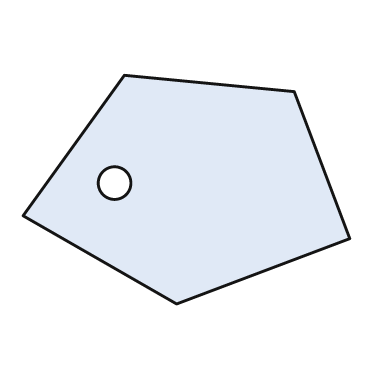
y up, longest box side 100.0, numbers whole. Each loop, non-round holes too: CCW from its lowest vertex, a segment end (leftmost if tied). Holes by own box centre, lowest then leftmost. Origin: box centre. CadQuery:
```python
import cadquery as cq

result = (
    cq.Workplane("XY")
    .moveTo(-3.0, -35.0)
    .lineTo(50.0, -15.0)
    .lineTo(33.0, 30.0)
    .lineTo(-19.0, 35.0)
    .lineTo(-50.0, -8.0)
    .close()
    .moveTo(-22.0, 2.0)
    .circle(5.0)
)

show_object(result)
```